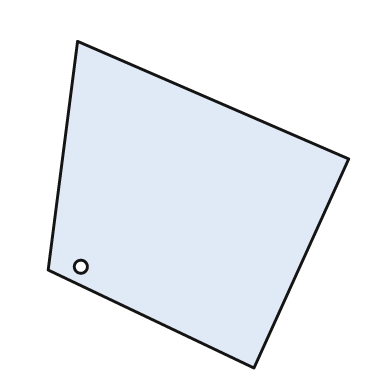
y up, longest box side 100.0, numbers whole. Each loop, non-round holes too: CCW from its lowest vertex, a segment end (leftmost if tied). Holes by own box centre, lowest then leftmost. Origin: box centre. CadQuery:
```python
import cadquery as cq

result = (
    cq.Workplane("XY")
    .moveTo(17.0, -50.0)
    .lineTo(46.0, 14.0)
    .lineTo(-37.0, 50.0)
    .lineTo(-46.0, -20.0)
    .close()
    .moveTo(-36.0, -19.0)
    .circle(2.0)
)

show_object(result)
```